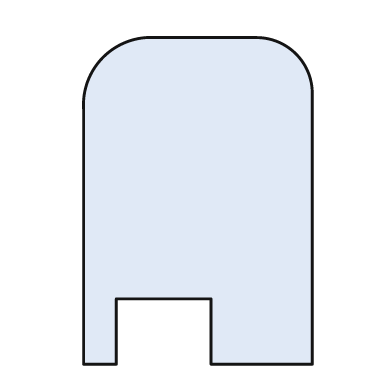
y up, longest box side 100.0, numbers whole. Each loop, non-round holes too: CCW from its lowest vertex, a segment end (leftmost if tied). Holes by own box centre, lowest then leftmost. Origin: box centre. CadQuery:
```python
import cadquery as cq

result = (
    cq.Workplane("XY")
    .moveTo(-35.0, -50.0)
    .lineTo(-25.0, -50.0)
    .lineTo(-25.0, -30.0)
    .lineTo(4.0, -30.0)
    .lineTo(4.0, -50.0)
    .lineTo(35.0, -50.0)
    .lineTo(35.0, 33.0)
    .threePointArc((30.0, 45.0), (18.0, 50.0))
    .lineTo(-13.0, 50.0)
    .threePointArc((-29.0, 44.0), (-35.0, 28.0))
    .close()
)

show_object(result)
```